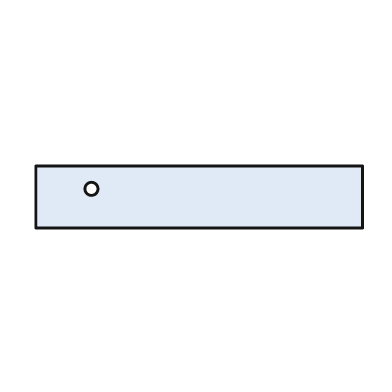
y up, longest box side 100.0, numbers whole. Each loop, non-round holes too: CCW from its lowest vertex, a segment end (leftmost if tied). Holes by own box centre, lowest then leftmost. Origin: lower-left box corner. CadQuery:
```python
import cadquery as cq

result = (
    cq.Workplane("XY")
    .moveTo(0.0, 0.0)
    .lineTo(100.0, 0.0)
    .lineTo(100.0, 19.0)
    .lineTo(0.0, 19.0)
    .close()
    .moveTo(17.0, 12.0)
    .circle(2.0)
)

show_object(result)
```